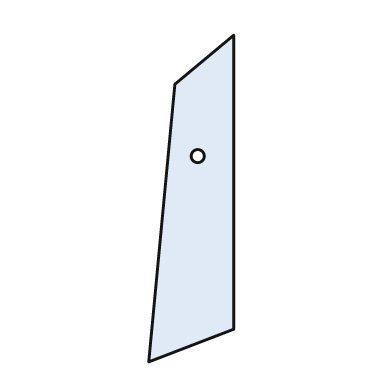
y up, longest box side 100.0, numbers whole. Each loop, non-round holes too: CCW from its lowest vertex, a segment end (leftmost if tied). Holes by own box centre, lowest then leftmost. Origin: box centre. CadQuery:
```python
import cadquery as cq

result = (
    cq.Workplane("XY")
    .moveTo(-13.0, -50.0)
    .lineTo(13.0, -40.0)
    .lineTo(13.0, 50.0)
    .lineTo(-5.0, 35.0)
    .close()
    .moveTo(2.0, 13.0)
    .circle(2.0)
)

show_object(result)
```